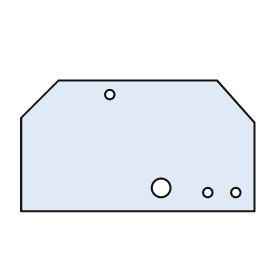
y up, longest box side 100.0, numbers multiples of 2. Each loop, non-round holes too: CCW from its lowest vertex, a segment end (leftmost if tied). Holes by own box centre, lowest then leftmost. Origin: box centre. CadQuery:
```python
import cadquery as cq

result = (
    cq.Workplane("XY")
    .moveTo(-50.0, -28.0)
    .lineTo(50.0, -28.0)
    .lineTo(50.0, 10.0)
    .lineTo(34.0, 28.0)
    .lineTo(-34.0, 28.0)
    .lineTo(-50.0, 12.0)
    .close()
    .moveTo(30.0, -20.0)
    .circle(2.0)
    .moveTo(42.0, -20.0)
    .circle(2.0)
    .moveTo(10.0, -18.0)
    .circle(4.0)
    .moveTo(-12.0, 22.0)
    .circle(2.0)
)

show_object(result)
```